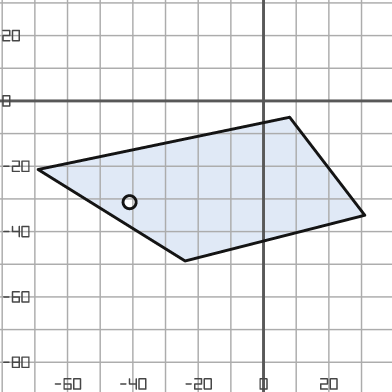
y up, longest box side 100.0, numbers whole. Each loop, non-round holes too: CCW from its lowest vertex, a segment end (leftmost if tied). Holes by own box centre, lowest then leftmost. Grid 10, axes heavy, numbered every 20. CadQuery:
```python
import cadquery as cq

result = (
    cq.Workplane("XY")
    .moveTo(-24.0, -49.0)
    .lineTo(31.0, -35.0)
    .lineTo(8.0, -5.0)
    .lineTo(-69.0, -21.0)
    .close()
    .moveTo(-41.0, -31.0)
    .circle(2.0)
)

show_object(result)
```